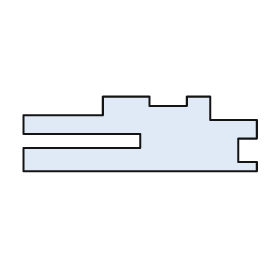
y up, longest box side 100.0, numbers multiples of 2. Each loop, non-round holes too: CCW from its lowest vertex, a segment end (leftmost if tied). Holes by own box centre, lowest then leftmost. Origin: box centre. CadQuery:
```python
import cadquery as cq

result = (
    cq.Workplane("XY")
    .moveTo(-50.0, -16.0)
    .lineTo(50.0, -16.0)
    .lineTo(50.0, -12.0)
    .lineTo(42.0, -12.0)
    .lineTo(42.0, -2.0)
    .lineTo(50.0, -2.0)
    .lineTo(50.0, 6.0)
    .lineTo(30.0, 6.0)
    .lineTo(30.0, 16.0)
    .lineTo(20.0, 16.0)
    .lineTo(20.0, 12.0)
    .lineTo(4.0, 12.0)
    .lineTo(4.0, 16.0)
    .lineTo(-16.0, 16.0)
    .lineTo(-16.0, 8.0)
    .lineTo(-50.0, 8.0)
    .lineTo(-50.0, 0.0)
    .lineTo(0.0, 0.0)
    .lineTo(0.0, -6.0)
    .lineTo(-50.0, -6.0)
    .close()
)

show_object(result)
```